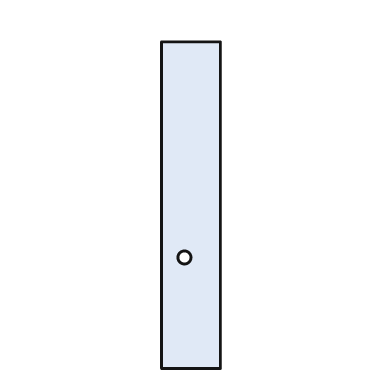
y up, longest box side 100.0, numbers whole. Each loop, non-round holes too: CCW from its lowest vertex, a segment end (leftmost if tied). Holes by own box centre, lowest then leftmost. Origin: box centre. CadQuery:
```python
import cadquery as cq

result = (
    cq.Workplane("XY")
    .moveTo(-9.0, -50.0)
    .lineTo(9.0, -50.0)
    .lineTo(9.0, 50.0)
    .lineTo(-9.0, 50.0)
    .close()
    .moveTo(-2.0, -16.0)
    .circle(2.0)
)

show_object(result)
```